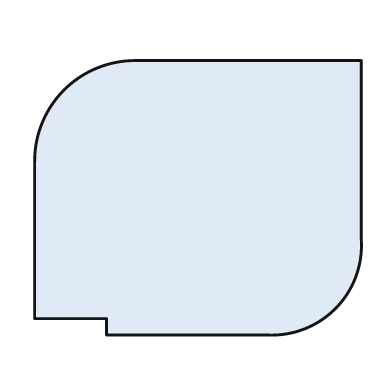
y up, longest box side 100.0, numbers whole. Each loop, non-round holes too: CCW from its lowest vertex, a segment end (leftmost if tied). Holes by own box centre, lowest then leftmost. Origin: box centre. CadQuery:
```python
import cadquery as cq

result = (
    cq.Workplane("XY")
    .moveTo(-28.0, -42.0)
    .lineTo(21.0, -42.0)
    .threePointArc((42.0, -34.0), (50.0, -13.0))
    .lineTo(50.0, 42.0)
    .lineTo(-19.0, 42.0)
    .threePointArc((-41.0, 33.0), (-50.0, 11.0))
    .lineTo(-50.0, -37.0)
    .lineTo(-28.0, -37.0)
    .close()
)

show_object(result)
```